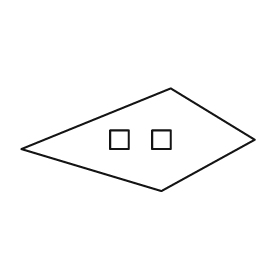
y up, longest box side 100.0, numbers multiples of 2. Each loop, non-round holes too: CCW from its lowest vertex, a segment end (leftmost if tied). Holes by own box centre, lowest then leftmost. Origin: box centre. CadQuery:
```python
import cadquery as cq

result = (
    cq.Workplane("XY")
    .moveTo(10.0, -22.0)
    .lineTo(50.0, 0.0)
    .lineTo(14.0, 22.0)
    .lineTo(-50.0, -4.0)
    .close()
    .moveTo(-12.0, -4.0)
    .lineTo(-4.0, -4.0)
    .lineTo(-4.0, 4.0)
    .lineTo(-12.0, 4.0)
    .close()
    .moveTo(6.0, -4.0)
    .lineTo(14.0, -4.0)
    .lineTo(14.0, 4.0)
    .lineTo(6.0, 4.0)
    .close()
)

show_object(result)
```